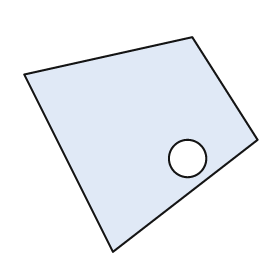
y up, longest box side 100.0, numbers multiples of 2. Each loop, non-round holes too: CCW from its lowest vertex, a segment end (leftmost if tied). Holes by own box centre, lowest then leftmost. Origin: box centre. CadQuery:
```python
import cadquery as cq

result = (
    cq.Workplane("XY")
    .moveTo(-12.0, -46.0)
    .lineTo(50.0, 2.0)
    .lineTo(22.0, 46.0)
    .lineTo(-50.0, 30.0)
    .close()
    .moveTo(20.0, -6.0)
    .circle(8.0)
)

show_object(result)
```